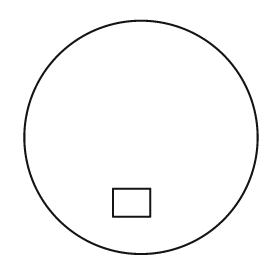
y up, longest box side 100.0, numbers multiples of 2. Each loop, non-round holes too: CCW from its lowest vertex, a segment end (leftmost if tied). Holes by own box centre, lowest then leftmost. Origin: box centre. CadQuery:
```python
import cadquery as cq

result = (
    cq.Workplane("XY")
    .moveTo(0.0, 0.0)
    .circle(50.0)
    .moveTo(-12.0, -34.0)
    .lineTo(4.0, -34.0)
    .lineTo(4.0, -22.0)
    .lineTo(-12.0, -22.0)
    .close()
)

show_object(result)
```